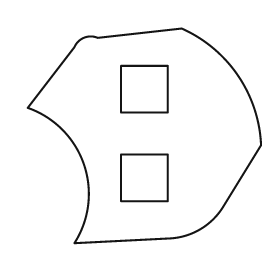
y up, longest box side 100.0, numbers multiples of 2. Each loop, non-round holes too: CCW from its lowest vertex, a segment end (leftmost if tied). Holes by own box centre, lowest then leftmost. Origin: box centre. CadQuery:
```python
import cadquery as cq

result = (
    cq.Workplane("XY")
    .moveTo(-30.0, -46.0)
    .lineTo(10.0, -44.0)
    .threePointArc((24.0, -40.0), (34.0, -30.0))
    .lineTo(50.0, -4.0)
    .threePointArc((40.0, 26.0), (16.0, 46.0))
    .lineTo(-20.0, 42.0)
    .threePointArc((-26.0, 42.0), (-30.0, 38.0))
    .lineTo(-50.0, 12.0)
    .threePointArc((-26.0, -12.0), (-30.0, -46.0))
    .close()
    .moveTo(-10.0, -28.0)
    .lineTo(10.0, -28.0)
    .lineTo(10.0, -8.0)
    .lineTo(-10.0, -8.0)
    .close()
    .moveTo(-10.0, 10.0)
    .lineTo(10.0, 10.0)
    .lineTo(10.0, 30.0)
    .lineTo(-10.0, 30.0)
    .close()
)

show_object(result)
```